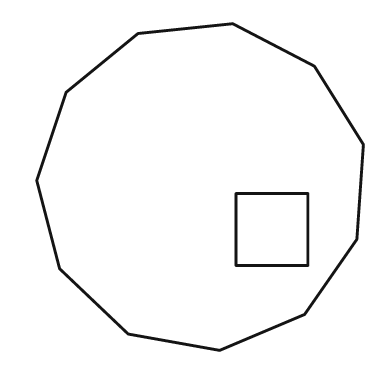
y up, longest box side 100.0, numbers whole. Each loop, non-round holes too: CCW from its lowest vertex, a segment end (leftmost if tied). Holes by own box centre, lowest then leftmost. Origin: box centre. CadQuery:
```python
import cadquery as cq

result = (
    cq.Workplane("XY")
    .moveTo(6.0, -50.0)
    .lineTo(32.0, -39.0)
    .lineTo(48.0, -16.0)
    .lineTo(50.0, 13.0)
    .lineTo(35.0, 37.0)
    .lineTo(10.0, 50.0)
    .lineTo(-19.0, 47.0)
    .lineTo(-41.0, 29.0)
    .lineTo(-50.0, 2.0)
    .lineTo(-43.0, -25.0)
    .lineTo(-22.0, -45.0)
    .close()
    .moveTo(11.0, -24.0)
    .lineTo(33.0, -24.0)
    .lineTo(33.0, -2.0)
    .lineTo(11.0, -2.0)
    .close()
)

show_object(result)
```